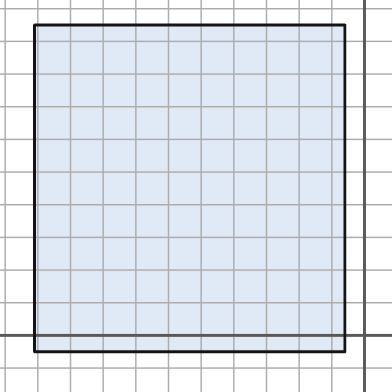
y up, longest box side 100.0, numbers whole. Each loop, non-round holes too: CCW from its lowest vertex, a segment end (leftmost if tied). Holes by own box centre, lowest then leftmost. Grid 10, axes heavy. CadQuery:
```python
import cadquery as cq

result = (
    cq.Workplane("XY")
    .moveTo(-101.0, -5.0)
    .lineTo(-6.0, -5.0)
    .lineTo(-6.0, 95.0)
    .lineTo(-101.0, 95.0)
    .close()
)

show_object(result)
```